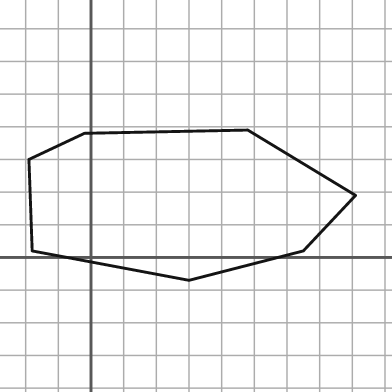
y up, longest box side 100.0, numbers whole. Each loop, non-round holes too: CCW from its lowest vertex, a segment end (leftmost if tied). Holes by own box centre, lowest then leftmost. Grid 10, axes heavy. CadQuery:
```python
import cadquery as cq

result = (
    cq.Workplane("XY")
    .moveTo(30.0, -7.0)
    .lineTo(65.0, 2.0)
    .lineTo(81.0, 19.0)
    .lineTo(48.0, 39.0)
    .lineTo(-2.0, 38.0)
    .lineTo(-19.0, 30.0)
    .lineTo(-18.0, 2.0)
    .close()
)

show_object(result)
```